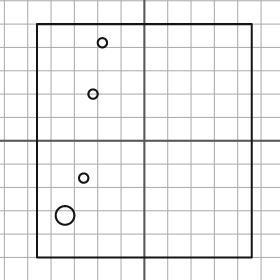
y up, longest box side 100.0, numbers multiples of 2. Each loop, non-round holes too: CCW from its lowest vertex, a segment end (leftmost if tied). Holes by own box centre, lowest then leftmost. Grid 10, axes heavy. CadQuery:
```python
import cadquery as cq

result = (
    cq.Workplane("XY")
    .moveTo(-46.0, -50.0)
    .lineTo(46.0, -50.0)
    .lineTo(46.0, 50.0)
    .lineTo(-46.0, 50.0)
    .close()
    .moveTo(-34.0, -32.0)
    .circle(4.0)
    .moveTo(-26.0, -16.0)
    .circle(2.0)
    .moveTo(-22.0, 20.0)
    .circle(2.0)
    .moveTo(-18.0, 42.0)
    .circle(2.0)
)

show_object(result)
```